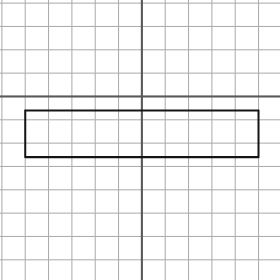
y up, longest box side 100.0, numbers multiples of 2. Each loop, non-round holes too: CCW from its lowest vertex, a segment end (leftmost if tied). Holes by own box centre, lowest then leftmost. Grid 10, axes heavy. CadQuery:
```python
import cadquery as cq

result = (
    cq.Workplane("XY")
    .moveTo(-50.0, -26.0)
    .lineTo(50.0, -26.0)
    .lineTo(50.0, -6.0)
    .lineTo(-50.0, -6.0)
    .close()
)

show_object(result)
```